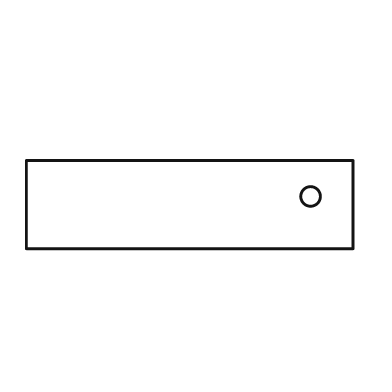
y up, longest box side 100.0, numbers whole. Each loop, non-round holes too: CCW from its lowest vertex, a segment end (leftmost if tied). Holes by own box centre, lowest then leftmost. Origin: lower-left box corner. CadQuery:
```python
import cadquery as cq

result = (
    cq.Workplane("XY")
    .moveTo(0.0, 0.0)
    .lineTo(100.0, 0.0)
    .lineTo(100.0, 27.0)
    .lineTo(0.0, 27.0)
    .close()
    .moveTo(87.0, 16.0)
    .circle(3.0)
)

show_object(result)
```